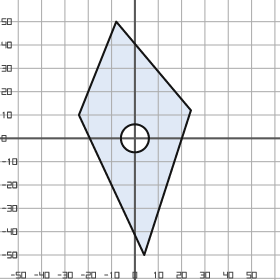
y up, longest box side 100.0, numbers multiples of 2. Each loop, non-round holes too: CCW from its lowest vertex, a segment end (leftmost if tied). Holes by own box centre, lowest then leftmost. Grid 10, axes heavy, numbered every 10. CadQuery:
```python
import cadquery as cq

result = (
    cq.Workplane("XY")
    .moveTo(4.0, -50.0)
    .lineTo(24.0, 12.0)
    .lineTo(-8.0, 50.0)
    .lineTo(-24.0, 10.0)
    .close()
    .moveTo(0.0, 0.0)
    .circle(6.0)
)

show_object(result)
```